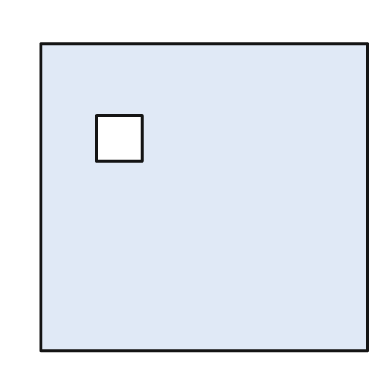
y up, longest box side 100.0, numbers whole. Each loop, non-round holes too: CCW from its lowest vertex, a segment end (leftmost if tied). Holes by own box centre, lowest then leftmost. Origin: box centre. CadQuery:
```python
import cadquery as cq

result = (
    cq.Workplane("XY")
    .moveTo(-50.0, -47.0)
    .lineTo(50.0, -47.0)
    .lineTo(50.0, 47.0)
    .lineTo(-50.0, 47.0)
    .close()
    .moveTo(-33.0, 11.0)
    .lineTo(-19.0, 11.0)
    .lineTo(-19.0, 25.0)
    .lineTo(-33.0, 25.0)
    .close()
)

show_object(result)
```